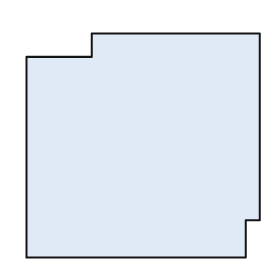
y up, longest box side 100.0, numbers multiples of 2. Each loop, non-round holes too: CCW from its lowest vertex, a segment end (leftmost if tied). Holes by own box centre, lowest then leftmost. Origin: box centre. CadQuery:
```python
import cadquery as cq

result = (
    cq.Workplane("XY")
    .moveTo(-50.0, -48.0)
    .lineTo(44.0, -48.0)
    .lineTo(44.0, -32.0)
    .lineTo(50.0, -32.0)
    .lineTo(50.0, 48.0)
    .lineTo(-22.0, 48.0)
    .lineTo(-22.0, 38.0)
    .lineTo(-50.0, 38.0)
    .close()
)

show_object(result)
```